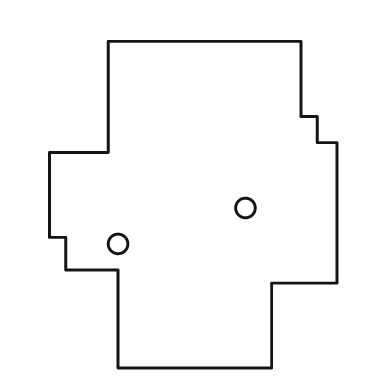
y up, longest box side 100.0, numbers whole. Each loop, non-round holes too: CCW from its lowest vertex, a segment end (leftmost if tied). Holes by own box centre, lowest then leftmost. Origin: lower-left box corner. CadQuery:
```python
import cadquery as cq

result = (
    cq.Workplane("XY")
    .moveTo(21.0, 0.0)
    .lineTo(68.0, 0.0)
    .lineTo(68.0, 26.0)
    .lineTo(88.0, 26.0)
    .lineTo(88.0, 69.0)
    .lineTo(82.0, 69.0)
    .lineTo(82.0, 77.0)
    .lineTo(77.0, 77.0)
    .lineTo(77.0, 100.0)
    .lineTo(18.0, 100.0)
    .lineTo(18.0, 66.0)
    .lineTo(0.0, 66.0)
    .lineTo(0.0, 40.0)
    .lineTo(5.0, 40.0)
    .lineTo(5.0, 30.0)
    .lineTo(21.0, 30.0)
    .close()
    .moveTo(21.0, 38.0)
    .circle(3.0)
    .moveTo(60.0, 49.0)
    .circle(3.0)
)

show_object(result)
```